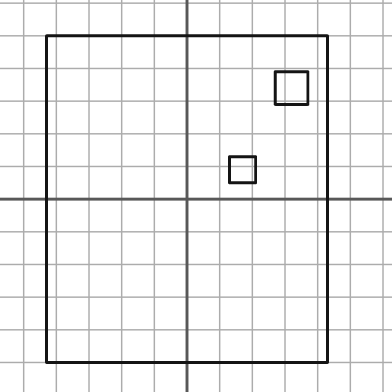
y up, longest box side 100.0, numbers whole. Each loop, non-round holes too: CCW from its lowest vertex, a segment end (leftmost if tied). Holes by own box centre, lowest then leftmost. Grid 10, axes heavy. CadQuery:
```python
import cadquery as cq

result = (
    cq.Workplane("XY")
    .moveTo(-43.0, -50.0)
    .lineTo(43.0, -50.0)
    .lineTo(43.0, 50.0)
    .lineTo(-43.0, 50.0)
    .close()
    .moveTo(13.0, 5.0)
    .lineTo(21.0, 5.0)
    .lineTo(21.0, 13.0)
    .lineTo(13.0, 13.0)
    .close()
    .moveTo(27.0, 29.0)
    .lineTo(37.0, 29.0)
    .lineTo(37.0, 39.0)
    .lineTo(27.0, 39.0)
    .close()
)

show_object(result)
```